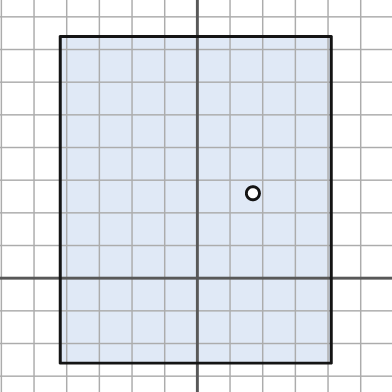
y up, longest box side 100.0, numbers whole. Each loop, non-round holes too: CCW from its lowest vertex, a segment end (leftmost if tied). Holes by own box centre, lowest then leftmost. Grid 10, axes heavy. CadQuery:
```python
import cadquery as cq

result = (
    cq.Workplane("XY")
    .moveTo(-42.0, -26.0)
    .lineTo(41.0, -26.0)
    .lineTo(41.0, 74.0)
    .lineTo(-42.0, 74.0)
    .close()
    .moveTo(17.0, 26.0)
    .circle(2.0)
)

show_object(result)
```